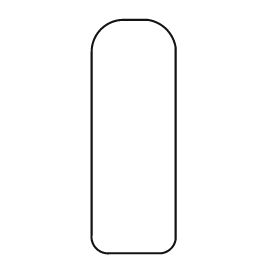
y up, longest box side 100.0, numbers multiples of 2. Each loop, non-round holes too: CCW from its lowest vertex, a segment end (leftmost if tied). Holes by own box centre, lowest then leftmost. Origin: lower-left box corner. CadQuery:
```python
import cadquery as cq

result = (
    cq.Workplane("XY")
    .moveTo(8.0, 0.0)
    .lineTo(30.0, 0.0)
    .threePointArc((34.0, 2.0), (36.0, 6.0))
    .lineTo(36.0, 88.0)
    .threePointArc((32.0, 96.0), (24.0, 100.0))
    .lineTo(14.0, 100.0)
    .threePointArc((4.0, 96.0), (0.0, 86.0))
    .lineTo(0.0, 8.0)
    .threePointArc((2.0, 2.0), (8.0, 0.0))
    .close()
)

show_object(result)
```